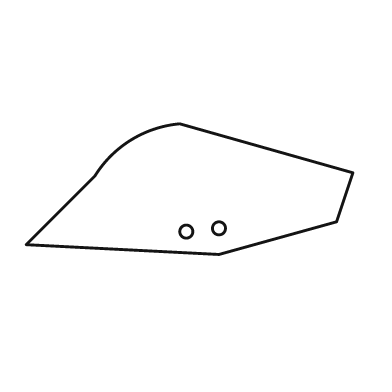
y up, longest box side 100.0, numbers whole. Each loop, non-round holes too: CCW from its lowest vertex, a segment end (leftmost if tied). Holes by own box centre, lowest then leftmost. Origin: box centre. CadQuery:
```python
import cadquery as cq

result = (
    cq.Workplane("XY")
    .moveTo(9.0, -20.0)
    .lineTo(45.0, -10.0)
    .lineTo(50.0, 5.0)
    .lineTo(-3.0, 20.0)
    .threePointArc((-18.0, 15.0), (-29.0, 4.0))
    .lineTo(-50.0, -17.0)
    .close()
    .moveTo(-1.0, -13.0)
    .circle(2.0)
    .moveTo(9.0, -12.0)
    .circle(2.0)
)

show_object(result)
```